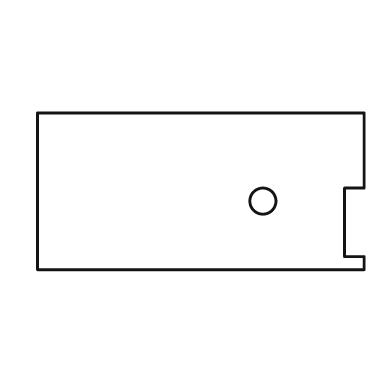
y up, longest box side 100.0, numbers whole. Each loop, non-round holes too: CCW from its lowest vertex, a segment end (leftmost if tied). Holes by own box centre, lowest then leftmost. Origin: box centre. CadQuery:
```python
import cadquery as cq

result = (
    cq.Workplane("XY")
    .moveTo(-50.0, -24.0)
    .lineTo(50.0, -24.0)
    .lineTo(50.0, -20.0)
    .lineTo(44.0, -20.0)
    .lineTo(44.0, 1.0)
    .lineTo(50.0, 1.0)
    .lineTo(50.0, 24.0)
    .lineTo(-50.0, 24.0)
    .close()
    .moveTo(19.0, -3.0)
    .circle(4.0)
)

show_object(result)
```